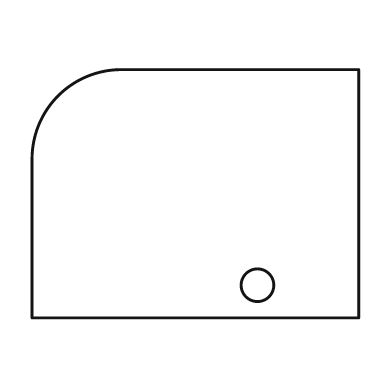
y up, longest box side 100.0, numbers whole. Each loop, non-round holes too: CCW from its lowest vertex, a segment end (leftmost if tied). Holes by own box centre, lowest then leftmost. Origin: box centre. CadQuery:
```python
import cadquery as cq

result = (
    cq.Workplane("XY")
    .moveTo(-50.0, -38.0)
    .lineTo(50.0, -38.0)
    .lineTo(50.0, 38.0)
    .lineTo(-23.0, 38.0)
    .threePointArc((-42.0, 30.0), (-50.0, 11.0))
    .close()
    .moveTo(19.0, -28.0)
    .circle(5.0)
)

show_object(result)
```